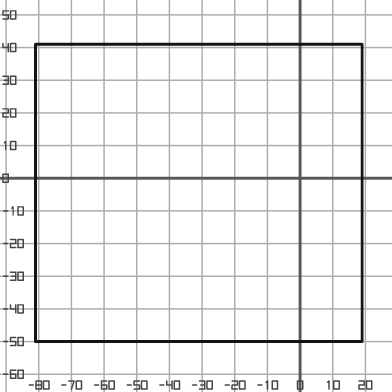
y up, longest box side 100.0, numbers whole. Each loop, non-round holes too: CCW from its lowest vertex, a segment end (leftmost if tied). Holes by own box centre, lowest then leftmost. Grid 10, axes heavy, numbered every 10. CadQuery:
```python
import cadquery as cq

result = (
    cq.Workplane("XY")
    .moveTo(-81.0, -50.0)
    .lineTo(19.0, -50.0)
    .lineTo(19.0, 41.0)
    .lineTo(-81.0, 41.0)
    .close()
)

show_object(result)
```